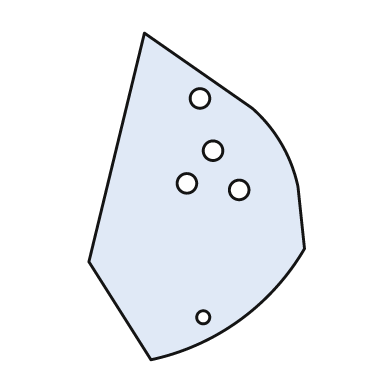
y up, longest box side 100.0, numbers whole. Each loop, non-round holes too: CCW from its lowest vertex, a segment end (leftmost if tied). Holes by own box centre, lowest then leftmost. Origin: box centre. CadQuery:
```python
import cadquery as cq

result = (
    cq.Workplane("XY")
    .moveTo(-14.0, -50.0)
    .threePointArc((13.0, -38.0), (33.0, -16.0))
    .lineTo(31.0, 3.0)
    .threePointArc((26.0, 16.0), (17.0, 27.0))
    .lineTo(-16.0, 50.0)
    .lineTo(-33.0, -20.0)
    .close()
    .moveTo(2.0, -37.0)
    .circle(2.0)
    .moveTo(13.0, 2.0)
    .circle(3.0)
    .moveTo(-3.0, 4.0)
    .circle(3.0)
    .moveTo(5.0, 14.0)
    .circle(3.0)
    .moveTo(1.0, 30.0)
    .circle(3.0)
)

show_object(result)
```